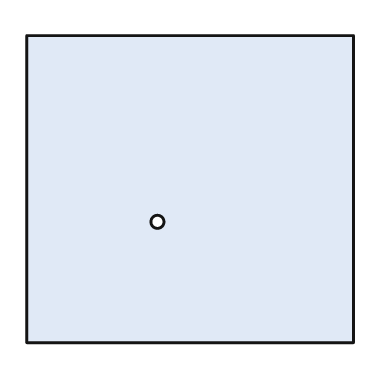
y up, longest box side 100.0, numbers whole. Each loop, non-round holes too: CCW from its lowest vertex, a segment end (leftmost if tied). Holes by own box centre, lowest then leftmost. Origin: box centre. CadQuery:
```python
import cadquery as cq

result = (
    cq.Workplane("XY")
    .moveTo(-50.0, -47.0)
    .lineTo(50.0, -47.0)
    .lineTo(50.0, 47.0)
    .lineTo(-50.0, 47.0)
    .close()
    .moveTo(-10.0, -10.0)
    .circle(2.0)
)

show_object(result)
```